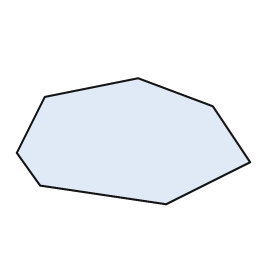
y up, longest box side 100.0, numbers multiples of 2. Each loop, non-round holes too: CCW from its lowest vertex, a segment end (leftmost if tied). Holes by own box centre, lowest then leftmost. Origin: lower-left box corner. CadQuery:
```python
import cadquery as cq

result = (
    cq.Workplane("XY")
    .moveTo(64.0, 0.0)
    .lineTo(100.0, 18.0)
    .lineTo(84.0, 42.0)
    .lineTo(52.0, 54.0)
    .lineTo(12.0, 46.0)
    .lineTo(0.0, 22.0)
    .lineTo(10.0, 8.0)
    .close()
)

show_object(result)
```